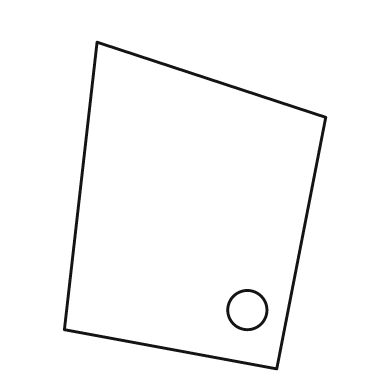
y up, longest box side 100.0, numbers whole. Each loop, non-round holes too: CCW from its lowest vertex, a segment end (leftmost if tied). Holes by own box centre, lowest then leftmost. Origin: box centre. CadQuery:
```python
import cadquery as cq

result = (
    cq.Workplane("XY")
    .moveTo(25.0, -50.0)
    .lineTo(40.0, 27.0)
    .lineTo(-30.0, 50.0)
    .lineTo(-40.0, -38.0)
    .close()
    .moveTo(16.0, -32.0)
    .circle(6.0)
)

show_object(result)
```